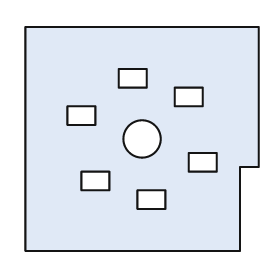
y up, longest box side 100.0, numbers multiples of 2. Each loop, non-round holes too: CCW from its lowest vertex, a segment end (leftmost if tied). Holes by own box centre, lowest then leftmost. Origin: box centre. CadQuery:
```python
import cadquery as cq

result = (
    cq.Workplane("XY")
    .moveTo(-50.0, -48.0)
    .lineTo(42.0, -48.0)
    .lineTo(42.0, -12.0)
    .lineTo(50.0, -12.0)
    .lineTo(50.0, 48.0)
    .lineTo(-50.0, 48.0)
    .close()
    .moveTo(-2.0, -30.0)
    .lineTo(10.0, -30.0)
    .lineTo(10.0, -22.0)
    .lineTo(-2.0, -22.0)
    .close()
    .moveTo(-26.0, -22.0)
    .lineTo(-14.0, -22.0)
    .lineTo(-14.0, -14.0)
    .lineTo(-26.0, -14.0)
    .close()
    .moveTo(20.0, -14.0)
    .lineTo(32.0, -14.0)
    .lineTo(32.0, -6.0)
    .lineTo(20.0, -6.0)
    .close()
    .moveTo(0.0, 0.0)
    .circle(8.0)
    .moveTo(-32.0, 6.0)
    .lineTo(-20.0, 6.0)
    .lineTo(-20.0, 14.0)
    .lineTo(-32.0, 14.0)
    .close()
    .moveTo(14.0, 14.0)
    .lineTo(26.0, 14.0)
    .lineTo(26.0, 22.0)
    .lineTo(14.0, 22.0)
    .close()
    .moveTo(-10.0, 22.0)
    .lineTo(2.0, 22.0)
    .lineTo(2.0, 30.0)
    .lineTo(-10.0, 30.0)
    .close()
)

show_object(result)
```